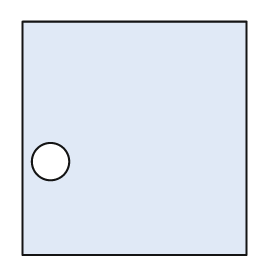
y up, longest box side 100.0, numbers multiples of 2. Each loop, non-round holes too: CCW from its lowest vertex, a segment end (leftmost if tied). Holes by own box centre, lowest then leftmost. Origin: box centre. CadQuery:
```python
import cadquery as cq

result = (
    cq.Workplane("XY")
    .moveTo(-48.0, -50.0)
    .lineTo(48.0, -50.0)
    .lineTo(48.0, 50.0)
    .lineTo(-48.0, 50.0)
    .close()
    .moveTo(-36.0, -10.0)
    .circle(8.0)
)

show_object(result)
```